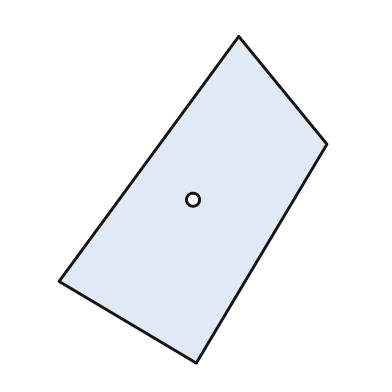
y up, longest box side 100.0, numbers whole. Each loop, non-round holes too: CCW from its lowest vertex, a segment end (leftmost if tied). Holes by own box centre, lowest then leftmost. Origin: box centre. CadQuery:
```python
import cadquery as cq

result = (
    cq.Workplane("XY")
    .moveTo(1.0, -50.0)
    .lineTo(41.0, 17.0)
    .lineTo(14.0, 50.0)
    .lineTo(-41.0, -25.0)
    .close()
    .moveTo(0.0, 0.0)
    .circle(2.0)
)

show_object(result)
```